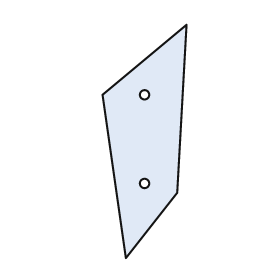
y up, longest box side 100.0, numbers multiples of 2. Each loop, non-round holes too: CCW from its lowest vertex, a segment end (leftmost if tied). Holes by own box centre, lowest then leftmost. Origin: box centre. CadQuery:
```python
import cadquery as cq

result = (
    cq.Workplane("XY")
    .moveTo(-8.0, -50.0)
    .lineTo(14.0, -22.0)
    .lineTo(18.0, 50.0)
    .lineTo(-18.0, 20.0)
    .close()
    .moveTo(0.0, -18.0)
    .circle(2.0)
    .moveTo(0.0, 20.0)
    .circle(2.0)
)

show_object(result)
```